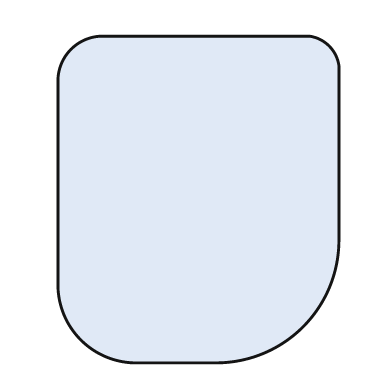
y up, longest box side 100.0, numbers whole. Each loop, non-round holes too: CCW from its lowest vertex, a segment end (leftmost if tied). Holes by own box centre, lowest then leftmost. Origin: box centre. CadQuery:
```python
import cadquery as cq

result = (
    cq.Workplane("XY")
    .moveTo(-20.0, -50.0)
    .lineTo(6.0, -50.0)
    .threePointArc((32.0, -39.0), (43.0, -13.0))
    .lineTo(43.0, 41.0)
    .threePointArc((40.0, 47.0), (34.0, 50.0))
    .lineTo(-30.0, 50.0)
    .threePointArc((-39.0, 46.0), (-43.0, 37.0))
    .lineTo(-43.0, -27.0)
    .threePointArc((-36.0, -43.0), (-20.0, -50.0))
    .close()
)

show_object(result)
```